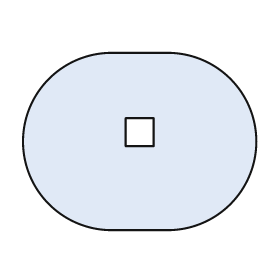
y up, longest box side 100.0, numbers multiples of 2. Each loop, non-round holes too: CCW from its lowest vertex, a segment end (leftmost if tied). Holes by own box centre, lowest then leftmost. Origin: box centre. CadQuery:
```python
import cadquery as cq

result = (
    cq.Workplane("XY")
    .moveTo(-12.0, -38.0)
    .lineTo(12.0, -38.0)
    .threePointArc((50.0, 0.0), (12.0, 38.0))
    .lineTo(-12.0, 38.0)
    .threePointArc((-50.0, 0.0), (-12.0, -38.0))
    .close()
    .moveTo(-6.0, -2.0)
    .lineTo(6.0, -2.0)
    .lineTo(6.0, 10.0)
    .lineTo(-6.0, 10.0)
    .close()
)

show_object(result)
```